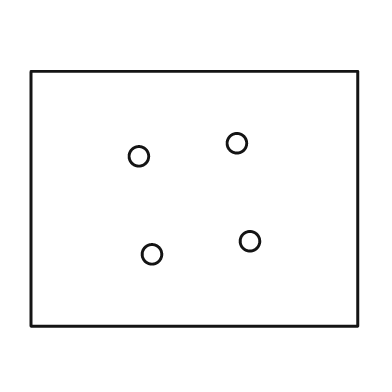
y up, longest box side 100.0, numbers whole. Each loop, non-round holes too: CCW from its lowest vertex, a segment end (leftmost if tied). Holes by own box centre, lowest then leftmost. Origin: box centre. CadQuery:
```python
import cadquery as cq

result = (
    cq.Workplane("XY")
    .moveTo(-50.0, -39.0)
    .lineTo(50.0, -39.0)
    .lineTo(50.0, 39.0)
    .lineTo(-50.0, 39.0)
    .close()
    .moveTo(-13.0, -17.0)
    .circle(3.0)
    .moveTo(17.0, -13.0)
    .circle(3.0)
    .moveTo(-17.0, 13.0)
    .circle(3.0)
    .moveTo(13.0, 17.0)
    .circle(3.0)
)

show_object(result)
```